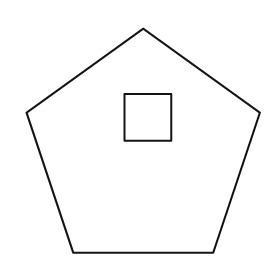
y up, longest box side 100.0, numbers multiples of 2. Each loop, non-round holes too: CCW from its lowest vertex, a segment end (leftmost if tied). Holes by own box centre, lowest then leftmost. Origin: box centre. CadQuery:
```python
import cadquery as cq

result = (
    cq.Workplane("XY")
    .moveTo(-30.0, -48.0)
    .lineTo(30.0, -48.0)
    .lineTo(50.0, 12.0)
    .lineTo(0.0, 48.0)
    .lineTo(-50.0, 12.0)
    .close()
    .moveTo(-8.0, 0.0)
    .lineTo(12.0, 0.0)
    .lineTo(12.0, 20.0)
    .lineTo(-8.0, 20.0)
    .close()
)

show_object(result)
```